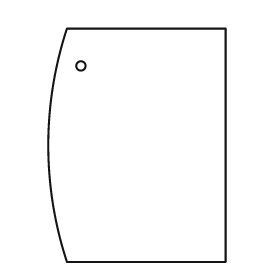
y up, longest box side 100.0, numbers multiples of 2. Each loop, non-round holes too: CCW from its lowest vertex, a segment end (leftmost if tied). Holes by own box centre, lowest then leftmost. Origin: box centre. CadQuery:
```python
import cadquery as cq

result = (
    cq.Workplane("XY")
    .moveTo(-30.0, -50.0)
    .lineTo(38.0, -50.0)
    .lineTo(38.0, 50.0)
    .lineTo(-30.0, 50.0)
    .threePointArc((-38.0, 0.0), (-30.0, -50.0))
    .close()
    .moveTo(-24.0, 34.0)
    .circle(2.0)
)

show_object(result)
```